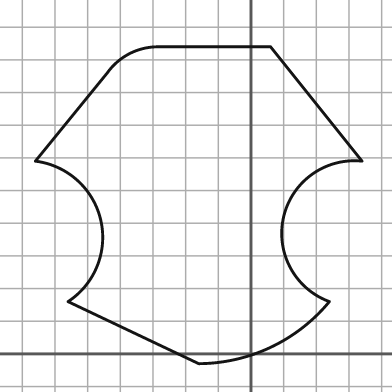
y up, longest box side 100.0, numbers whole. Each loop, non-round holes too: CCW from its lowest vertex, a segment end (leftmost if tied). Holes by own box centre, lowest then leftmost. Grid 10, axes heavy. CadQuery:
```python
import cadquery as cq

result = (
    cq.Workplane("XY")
    .moveTo(-16.0, -3.0)
    .threePointArc((6.0, 2.0), (24.0, 16.0))
    .threePointArc((10.0, 42.0), (34.0, 59.0))
    .lineTo(6.0, 94.0)
    .lineTo(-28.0, 94.0)
    .threePointArc((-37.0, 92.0), (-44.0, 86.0))
    .lineTo(-66.0, 59.0)
    .threePointArc((-46.0, 41.0), (-56.0, 16.0))
    .close()
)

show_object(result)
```